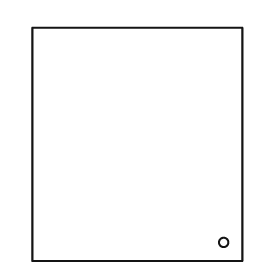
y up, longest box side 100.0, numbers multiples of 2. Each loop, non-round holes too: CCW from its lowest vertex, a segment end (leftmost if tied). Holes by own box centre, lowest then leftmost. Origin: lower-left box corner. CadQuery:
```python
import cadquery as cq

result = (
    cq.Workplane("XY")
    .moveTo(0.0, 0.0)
    .lineTo(90.0, 0.0)
    .lineTo(90.0, 100.0)
    .lineTo(0.0, 100.0)
    .close()
    .moveTo(82.0, 8.0)
    .circle(2.0)
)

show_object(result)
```